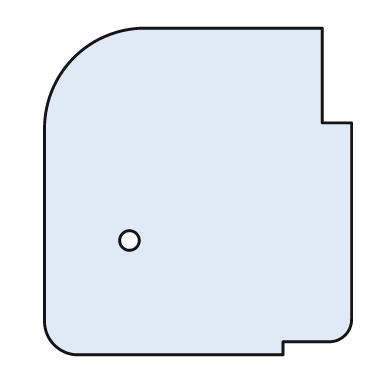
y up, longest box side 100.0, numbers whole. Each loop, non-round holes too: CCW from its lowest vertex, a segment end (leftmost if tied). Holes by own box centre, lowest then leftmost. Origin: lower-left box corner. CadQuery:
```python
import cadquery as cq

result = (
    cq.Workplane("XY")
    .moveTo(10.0, 0.0)
    .lineTo(73.0, 0.0)
    .lineTo(73.0, 4.0)
    .lineTo(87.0, 4.0)
    .threePointArc((92.0, 6.0), (94.0, 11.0))
    .lineTo(94.0, 71.0)
    .lineTo(85.0, 71.0)
    .lineTo(85.0, 100.0)
    .lineTo(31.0, 100.0)
    .threePointArc((9.0, 91.0), (0.0, 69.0))
    .lineTo(0.0, 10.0)
    .threePointArc((3.0, 3.0), (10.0, 0.0))
    .close()
    .moveTo(26.0, 35.0)
    .circle(3.0)
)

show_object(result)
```